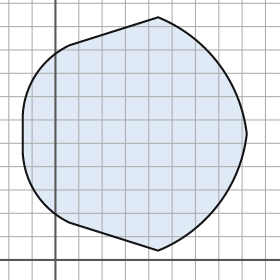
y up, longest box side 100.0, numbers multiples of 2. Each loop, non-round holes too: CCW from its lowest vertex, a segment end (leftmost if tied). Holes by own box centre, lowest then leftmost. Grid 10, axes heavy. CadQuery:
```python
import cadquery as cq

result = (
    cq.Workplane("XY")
    .moveTo(44.0, 4.0)
    .threePointArc((70.0, 24.0), (82.0, 54.0))
    .threePointArc((70.0, 84.0), (44.0, 104.0))
    .lineTo(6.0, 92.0)
    .threePointArc((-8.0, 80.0), (-14.0, 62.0))
    .lineTo(-14.0, 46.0)
    .threePointArc((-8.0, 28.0), (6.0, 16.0))
    .close()
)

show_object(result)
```